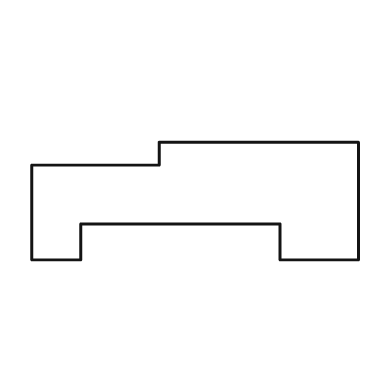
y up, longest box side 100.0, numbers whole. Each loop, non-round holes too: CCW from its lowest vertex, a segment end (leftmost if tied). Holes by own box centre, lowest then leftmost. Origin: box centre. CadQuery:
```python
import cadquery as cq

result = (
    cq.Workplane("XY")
    .moveTo(-50.0, -18.0)
    .lineTo(-35.0, -18.0)
    .lineTo(-35.0, -7.0)
    .lineTo(26.0, -7.0)
    .lineTo(26.0, -18.0)
    .lineTo(50.0, -18.0)
    .lineTo(50.0, 18.0)
    .lineTo(-11.0, 18.0)
    .lineTo(-11.0, 11.0)
    .lineTo(-50.0, 11.0)
    .close()
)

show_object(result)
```